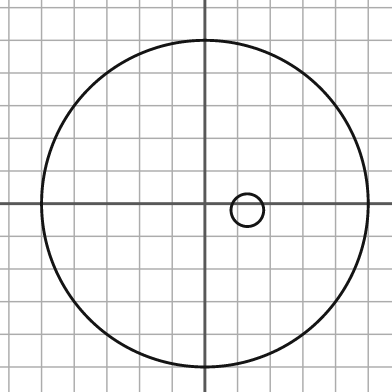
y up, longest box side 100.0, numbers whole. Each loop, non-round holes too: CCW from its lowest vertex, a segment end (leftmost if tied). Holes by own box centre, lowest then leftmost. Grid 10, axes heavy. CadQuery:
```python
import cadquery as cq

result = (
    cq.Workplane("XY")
    .moveTo(0.0, 0.0)
    .circle(50.0)
    .moveTo(13.0, -2.0)
    .circle(5.0)
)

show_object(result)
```